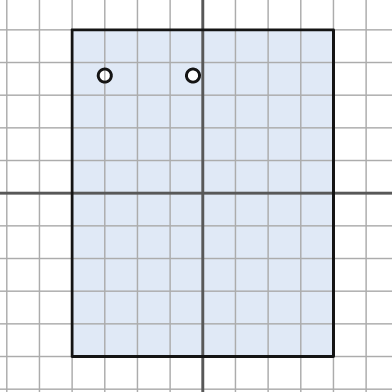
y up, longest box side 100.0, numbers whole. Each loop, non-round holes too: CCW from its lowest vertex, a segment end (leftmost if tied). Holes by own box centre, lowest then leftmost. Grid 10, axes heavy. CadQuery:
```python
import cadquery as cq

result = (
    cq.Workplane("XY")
    .moveTo(-40.0, -50.0)
    .lineTo(40.0, -50.0)
    .lineTo(40.0, 50.0)
    .lineTo(-40.0, 50.0)
    .close()
    .moveTo(-30.0, 36.0)
    .circle(2.0)
    .moveTo(-3.0, 36.0)
    .circle(2.0)
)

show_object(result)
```